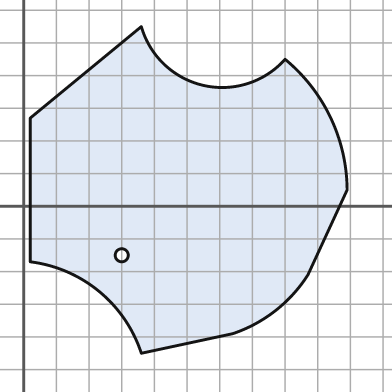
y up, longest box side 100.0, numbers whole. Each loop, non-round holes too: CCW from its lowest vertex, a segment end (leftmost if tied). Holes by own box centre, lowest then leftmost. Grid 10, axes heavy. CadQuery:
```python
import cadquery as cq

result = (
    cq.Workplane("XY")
    .moveTo(36.0, -45.0)
    .lineTo(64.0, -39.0)
    .threePointArc((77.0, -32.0), (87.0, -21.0))
    .lineTo(99.0, 5.0)
    .threePointArc((94.0, 27.0), (80.0, 45.0))
    .threePointArc((55.0, 37.0), (36.0, 55.0))
    .lineTo(2.0, 27.0)
    .lineTo(2.0, -17.0)
    .threePointArc((23.0, -26.0), (36.0, -45.0))
    .close()
    .moveTo(30.0, -15.0)
    .circle(2.0)
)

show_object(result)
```